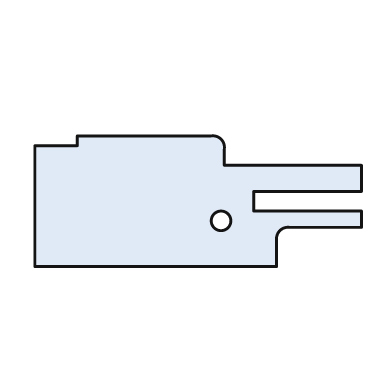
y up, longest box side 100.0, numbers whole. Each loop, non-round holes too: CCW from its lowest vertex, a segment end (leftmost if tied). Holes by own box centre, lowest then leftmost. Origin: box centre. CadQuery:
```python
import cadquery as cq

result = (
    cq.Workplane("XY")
    .moveTo(-50.0, -20.0)
    .lineTo(24.0, -20.0)
    .lineTo(24.0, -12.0)
    .threePointArc((25.0, -9.0), (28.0, -8.0))
    .lineTo(50.0, -8.0)
    .lineTo(50.0, -3.0)
    .lineTo(17.0, -3.0)
    .lineTo(17.0, 3.0)
    .lineTo(50.0, 3.0)
    .lineTo(50.0, 11.0)
    .lineTo(8.0, 11.0)
    .lineTo(8.0, 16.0)
    .threePointArc((7.0, 19.0), (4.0, 20.0))
    .lineTo(-37.0, 20.0)
    .lineTo(-37.0, 17.0)
    .lineTo(-50.0, 17.0)
    .close()
    .moveTo(7.0, -6.0)
    .circle(3.0)
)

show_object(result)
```